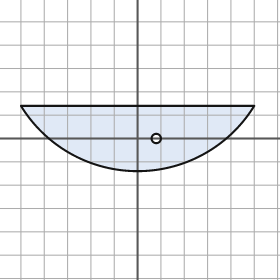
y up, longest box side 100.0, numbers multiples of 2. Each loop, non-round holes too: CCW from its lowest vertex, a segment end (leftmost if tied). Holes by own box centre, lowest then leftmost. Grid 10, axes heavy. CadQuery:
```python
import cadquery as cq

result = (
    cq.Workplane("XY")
    .moveTo(-50.0, 14.0)
    .threePointArc((0.0, -14.0), (50.0, 14.0))
    .close()
    .moveTo(8.0, 0.0)
    .circle(2.0)
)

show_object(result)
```